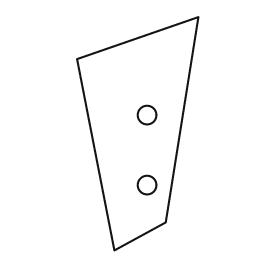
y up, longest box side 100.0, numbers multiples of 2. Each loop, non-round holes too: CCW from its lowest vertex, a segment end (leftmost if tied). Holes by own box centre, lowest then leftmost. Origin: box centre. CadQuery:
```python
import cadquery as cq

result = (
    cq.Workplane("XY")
    .moveTo(-10.0, -50.0)
    .lineTo(12.0, -38.0)
    .lineTo(26.0, 50.0)
    .lineTo(-26.0, 32.0)
    .close()
    .moveTo(4.0, -22.0)
    .circle(4.0)
    .moveTo(4.0, 8.0)
    .circle(4.0)
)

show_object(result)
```